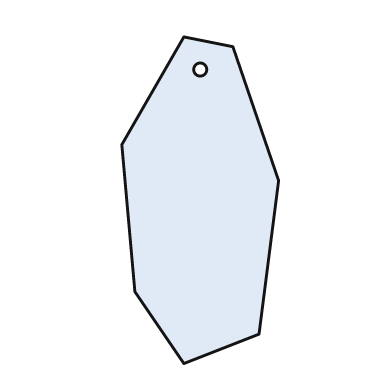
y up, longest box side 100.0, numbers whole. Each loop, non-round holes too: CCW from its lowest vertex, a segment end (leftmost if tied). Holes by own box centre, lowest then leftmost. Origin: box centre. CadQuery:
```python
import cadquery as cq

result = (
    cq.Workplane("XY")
    .moveTo(-5.0, -50.0)
    .lineTo(18.0, -41.0)
    .lineTo(24.0, 6.0)
    .lineTo(10.0, 47.0)
    .lineTo(-5.0, 50.0)
    .lineTo(-24.0, 17.0)
    .lineTo(-20.0, -28.0)
    .close()
    .moveTo(0.0, 40.0)
    .circle(2.0)
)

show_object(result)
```